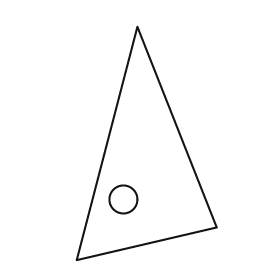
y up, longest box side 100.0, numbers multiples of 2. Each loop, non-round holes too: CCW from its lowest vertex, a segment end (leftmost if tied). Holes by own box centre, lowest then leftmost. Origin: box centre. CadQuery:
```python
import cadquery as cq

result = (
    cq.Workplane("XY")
    .moveTo(-30.0, -50.0)
    .lineTo(30.0, -36.0)
    .lineTo(-4.0, 50.0)
    .close()
    .moveTo(-10.0, -24.0)
    .circle(6.0)
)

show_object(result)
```